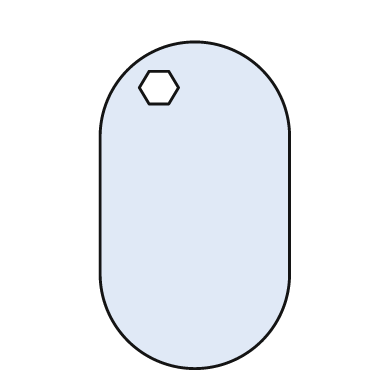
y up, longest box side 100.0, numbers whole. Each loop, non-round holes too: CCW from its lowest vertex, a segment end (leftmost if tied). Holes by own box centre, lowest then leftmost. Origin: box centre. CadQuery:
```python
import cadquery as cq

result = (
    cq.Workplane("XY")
    .moveTo(-29.0, -21.0)
    .threePointArc((0.0, -50.0), (29.0, -21.0))
    .lineTo(29.0, 21.0)
    .threePointArc((0.0, 50.0), (-29.0, 21.0))
    .close()
    .moveTo(-14.0, 31.0)
    .lineTo(-8.0, 31.0)
    .lineTo(-5.0, 36.0)
    .lineTo(-8.0, 41.0)
    .lineTo(-14.0, 41.0)
    .lineTo(-17.0, 36.0)
    .close()
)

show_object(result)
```